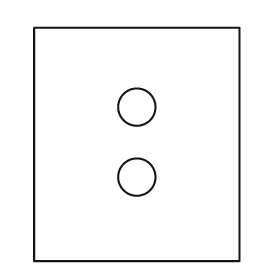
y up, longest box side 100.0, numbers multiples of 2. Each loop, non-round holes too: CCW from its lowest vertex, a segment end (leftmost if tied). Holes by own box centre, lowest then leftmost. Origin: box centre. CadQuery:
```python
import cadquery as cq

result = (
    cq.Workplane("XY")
    .moveTo(-44.0, -50.0)
    .lineTo(44.0, -50.0)
    .lineTo(44.0, 50.0)
    .lineTo(-44.0, 50.0)
    .close()
    .moveTo(0.0, -14.0)
    .circle(8.0)
    .moveTo(0.0, 16.0)
    .circle(8.0)
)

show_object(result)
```